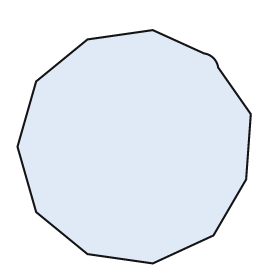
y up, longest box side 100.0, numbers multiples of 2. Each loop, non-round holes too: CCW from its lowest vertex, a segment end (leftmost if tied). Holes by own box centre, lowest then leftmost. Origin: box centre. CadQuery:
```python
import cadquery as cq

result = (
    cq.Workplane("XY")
    .moveTo(8.0, -50.0)
    .lineTo(34.0, -38.0)
    .lineTo(48.0, -14.0)
    .lineTo(50.0, 14.0)
    .lineTo(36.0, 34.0)
    .threePointArc((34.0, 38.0), (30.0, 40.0))
    .lineTo(8.0, 50.0)
    .lineTo(-20.0, 46.0)
    .lineTo(-42.0, 28.0)
    .lineTo(-50.0, 0.0)
    .lineTo(-42.0, -28.0)
    .lineTo(-20.0, -46.0)
    .close()
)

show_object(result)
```